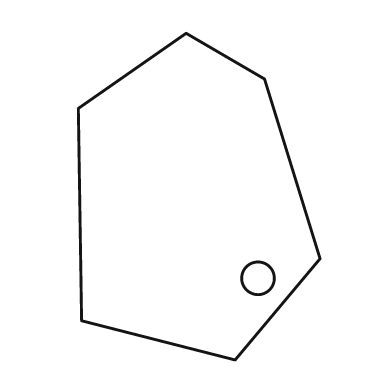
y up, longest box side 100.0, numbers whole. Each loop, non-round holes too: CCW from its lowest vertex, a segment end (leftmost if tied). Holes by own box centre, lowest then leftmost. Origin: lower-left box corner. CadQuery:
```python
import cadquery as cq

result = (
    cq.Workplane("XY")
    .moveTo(48.0, 0.0)
    .lineTo(74.0, 31.0)
    .lineTo(57.0, 86.0)
    .lineTo(33.0, 100.0)
    .lineTo(0.0, 77.0)
    .lineTo(1.0, 12.0)
    .close()
    .moveTo(55.0, 25.0)
    .circle(5.0)
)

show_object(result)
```